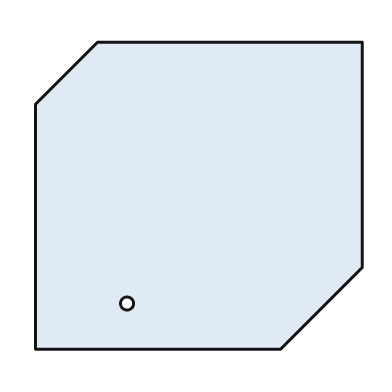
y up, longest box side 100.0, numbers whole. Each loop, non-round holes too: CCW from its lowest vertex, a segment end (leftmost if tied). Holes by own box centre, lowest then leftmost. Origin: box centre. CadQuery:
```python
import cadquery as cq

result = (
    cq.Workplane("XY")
    .moveTo(-50.0, -47.0)
    .lineTo(25.0, -47.0)
    .lineTo(50.0, -22.0)
    .lineTo(50.0, 47.0)
    .lineTo(-31.0, 47.0)
    .lineTo(-50.0, 28.0)
    .close()
    .moveTo(-22.0, -33.0)
    .circle(2.0)
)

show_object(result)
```